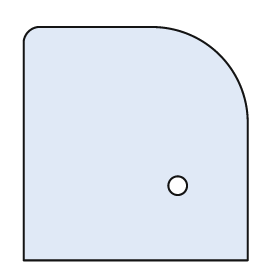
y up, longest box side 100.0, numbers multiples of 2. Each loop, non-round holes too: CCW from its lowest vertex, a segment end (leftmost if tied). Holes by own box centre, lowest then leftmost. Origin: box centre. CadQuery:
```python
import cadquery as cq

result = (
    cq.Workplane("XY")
    .moveTo(-48.0, -50.0)
    .lineTo(48.0, -50.0)
    .lineTo(48.0, 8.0)
    .threePointArc((36.0, 38.0), (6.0, 50.0))
    .lineTo(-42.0, 50.0)
    .threePointArc((-46.0, 48.0), (-48.0, 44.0))
    .close()
    .moveTo(18.0, -18.0)
    .circle(4.0)
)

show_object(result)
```